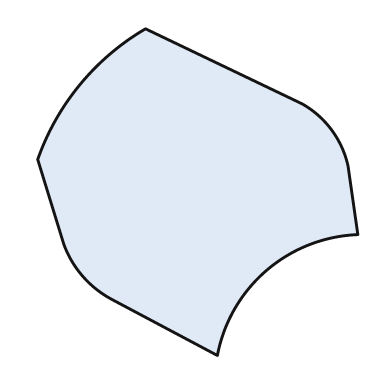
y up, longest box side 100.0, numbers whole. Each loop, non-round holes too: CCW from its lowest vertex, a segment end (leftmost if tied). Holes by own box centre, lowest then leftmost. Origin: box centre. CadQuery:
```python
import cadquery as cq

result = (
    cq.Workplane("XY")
    .moveTo(6.0, -50.0)
    .threePointArc((21.0, -24.0), (49.0, -13.0))
    .lineTo(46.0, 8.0)
    .threePointArc((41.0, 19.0), (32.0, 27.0))
    .lineTo(-16.0, 50.0)
    .threePointArc((-36.0, 33.0), (-49.0, 10.0))
    .lineTo(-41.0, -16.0)
    .threePointArc((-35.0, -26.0), (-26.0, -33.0))
    .close()
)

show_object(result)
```